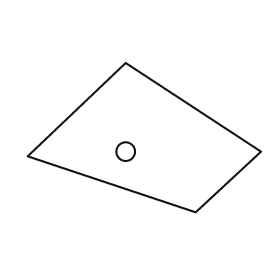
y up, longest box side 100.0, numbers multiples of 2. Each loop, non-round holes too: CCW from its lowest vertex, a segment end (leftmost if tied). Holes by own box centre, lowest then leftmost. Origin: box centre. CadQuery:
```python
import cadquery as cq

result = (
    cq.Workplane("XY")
    .moveTo(22.0, -32.0)
    .lineTo(50.0, -6.0)
    .lineTo(-8.0, 32.0)
    .lineTo(-50.0, -8.0)
    .close()
    .moveTo(-8.0, -6.0)
    .circle(4.0)
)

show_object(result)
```